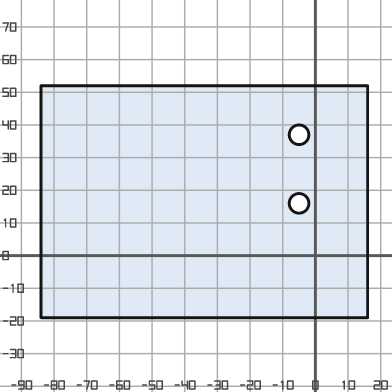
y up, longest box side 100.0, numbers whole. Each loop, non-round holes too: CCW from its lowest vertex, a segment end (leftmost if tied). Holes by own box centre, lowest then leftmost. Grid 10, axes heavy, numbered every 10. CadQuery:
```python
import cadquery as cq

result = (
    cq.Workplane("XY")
    .moveTo(-84.0, -19.0)
    .lineTo(16.0, -19.0)
    .lineTo(16.0, 52.0)
    .lineTo(-84.0, 52.0)
    .close()
    .moveTo(-5.0, 16.0)
    .circle(3.0)
    .moveTo(-5.0, 37.0)
    .circle(3.0)
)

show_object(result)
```